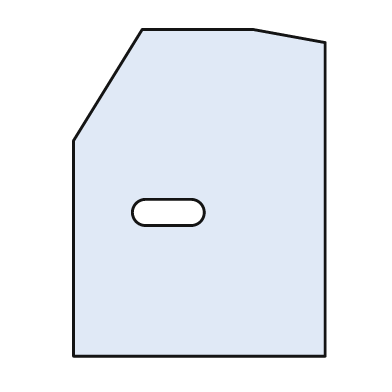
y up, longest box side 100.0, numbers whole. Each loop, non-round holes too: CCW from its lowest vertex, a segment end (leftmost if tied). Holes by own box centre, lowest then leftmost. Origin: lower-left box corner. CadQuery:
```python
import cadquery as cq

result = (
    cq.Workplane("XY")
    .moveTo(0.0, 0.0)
    .lineTo(77.0, 0.0)
    .lineTo(77.0, 96.0)
    .lineTo(55.0, 100.0)
    .lineTo(21.0, 100.0)
    .lineTo(0.0, 66.0)
    .close()
    .moveTo(22.0, 40.0)
    .lineTo(36.0, 40.0)
    .threePointArc((40.0, 44.0), (36.0, 48.0))
    .lineTo(22.0, 48.0)
    .threePointArc((18.0, 44.0), (22.0, 40.0))
    .close()
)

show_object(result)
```